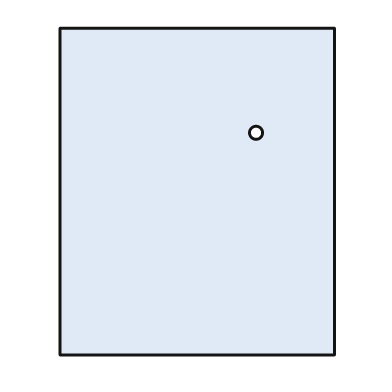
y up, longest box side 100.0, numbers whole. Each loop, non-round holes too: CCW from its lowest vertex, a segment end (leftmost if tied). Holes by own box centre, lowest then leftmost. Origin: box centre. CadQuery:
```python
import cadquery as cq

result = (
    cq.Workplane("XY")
    .moveTo(-42.0, -50.0)
    .lineTo(42.0, -50.0)
    .lineTo(42.0, 50.0)
    .lineTo(-42.0, 50.0)
    .close()
    .moveTo(18.0, 18.0)
    .circle(2.0)
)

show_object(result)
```